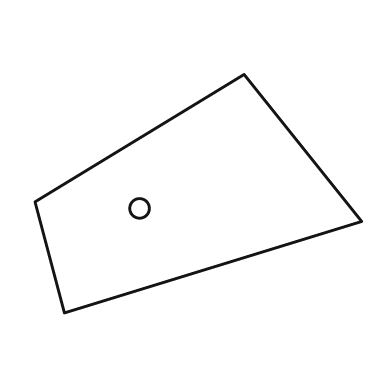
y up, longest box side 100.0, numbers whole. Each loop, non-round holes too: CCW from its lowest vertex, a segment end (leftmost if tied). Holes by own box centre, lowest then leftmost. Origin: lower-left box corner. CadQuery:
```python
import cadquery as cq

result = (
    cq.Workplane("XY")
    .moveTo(9.0, 0.0)
    .lineTo(100.0, 28.0)
    .lineTo(64.0, 73.0)
    .lineTo(0.0, 34.0)
    .close()
    .moveTo(32.0, 32.0)
    .circle(3.0)
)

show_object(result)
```